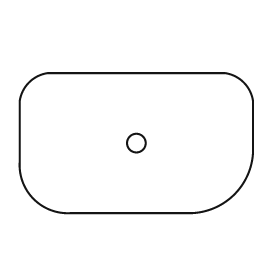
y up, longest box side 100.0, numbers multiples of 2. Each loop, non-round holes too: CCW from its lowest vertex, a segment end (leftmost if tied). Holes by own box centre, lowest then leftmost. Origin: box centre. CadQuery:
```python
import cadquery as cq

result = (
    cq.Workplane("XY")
    .moveTo(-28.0, -30.0)
    .lineTo(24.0, -30.0)
    .threePointArc((42.0, -22.0), (50.0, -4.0))
    .lineTo(50.0, 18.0)
    .threePointArc((46.0, 26.0), (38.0, 30.0))
    .lineTo(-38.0, 30.0)
    .threePointArc((-46.0, 26.0), (-50.0, 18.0))
    .lineTo(-50.0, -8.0)
    .threePointArc((-44.0, -24.0), (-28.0, -30.0))
    .close()
    .moveTo(0.0, 0.0)
    .circle(4.0)
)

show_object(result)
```